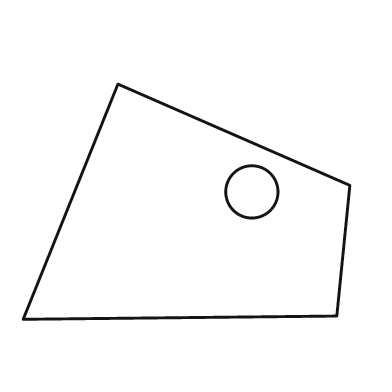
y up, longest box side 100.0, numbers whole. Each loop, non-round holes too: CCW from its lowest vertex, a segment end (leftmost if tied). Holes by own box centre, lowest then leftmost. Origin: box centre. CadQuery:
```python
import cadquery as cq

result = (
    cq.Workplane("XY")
    .moveTo(-50.0, -36.0)
    .lineTo(46.0, -35.0)
    .lineTo(50.0, 5.0)
    .lineTo(-21.0, 36.0)
    .close()
    .moveTo(20.0, 3.0)
    .circle(8.0)
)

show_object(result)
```